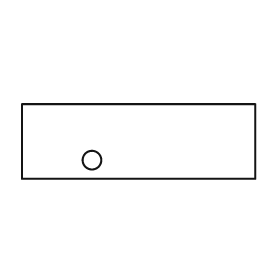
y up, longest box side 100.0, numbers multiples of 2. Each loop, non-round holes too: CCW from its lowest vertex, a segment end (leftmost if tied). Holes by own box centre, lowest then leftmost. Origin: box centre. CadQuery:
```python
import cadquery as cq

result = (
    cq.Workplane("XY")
    .moveTo(-50.0, -16.0)
    .lineTo(50.0, -16.0)
    .lineTo(50.0, 16.0)
    .lineTo(-50.0, 16.0)
    .close()
    .moveTo(-20.0, -8.0)
    .circle(4.0)
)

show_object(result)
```